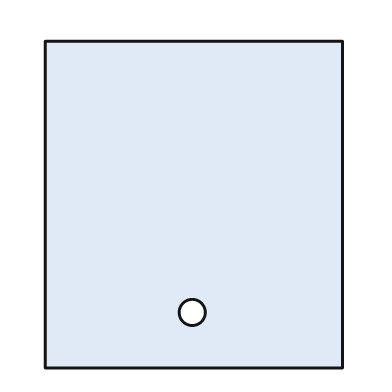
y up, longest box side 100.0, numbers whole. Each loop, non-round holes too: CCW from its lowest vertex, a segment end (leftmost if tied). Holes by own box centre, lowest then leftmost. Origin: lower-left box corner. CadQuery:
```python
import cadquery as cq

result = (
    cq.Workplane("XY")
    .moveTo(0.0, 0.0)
    .lineTo(91.0, 0.0)
    .lineTo(91.0, 100.0)
    .lineTo(0.0, 100.0)
    .close()
    .moveTo(45.0, 17.0)
    .circle(4.0)
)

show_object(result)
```